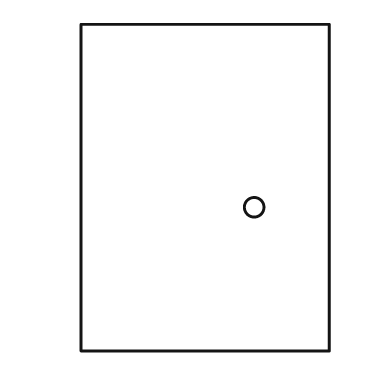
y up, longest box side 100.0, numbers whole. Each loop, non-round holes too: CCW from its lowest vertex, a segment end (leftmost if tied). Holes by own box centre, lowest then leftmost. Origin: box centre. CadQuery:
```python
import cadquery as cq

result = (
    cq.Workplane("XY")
    .moveTo(-38.0, -50.0)
    .lineTo(38.0, -50.0)
    .lineTo(38.0, 50.0)
    .lineTo(-38.0, 50.0)
    .close()
    .moveTo(15.0, -6.0)
    .circle(3.0)
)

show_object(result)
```